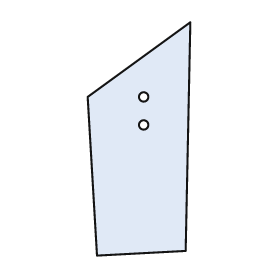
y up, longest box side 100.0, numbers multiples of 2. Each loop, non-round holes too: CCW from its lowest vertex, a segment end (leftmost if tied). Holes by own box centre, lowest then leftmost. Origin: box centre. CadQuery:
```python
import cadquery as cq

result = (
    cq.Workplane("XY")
    .moveTo(-18.0, -50.0)
    .lineTo(20.0, -48.0)
    .lineTo(22.0, 50.0)
    .lineTo(-22.0, 18.0)
    .close()
    .moveTo(2.0, 6.0)
    .circle(2.0)
    .moveTo(2.0, 18.0)
    .circle(2.0)
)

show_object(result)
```